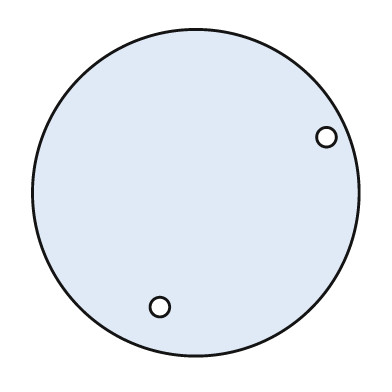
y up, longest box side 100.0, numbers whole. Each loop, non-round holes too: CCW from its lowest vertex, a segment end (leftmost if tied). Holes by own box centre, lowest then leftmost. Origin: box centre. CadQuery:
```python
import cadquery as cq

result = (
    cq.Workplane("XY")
    .moveTo(0.0, 0.0)
    .circle(50.0)
    .moveTo(-11.0, -35.0)
    .circle(3.0)
    .moveTo(40.0, 17.0)
    .circle(3.0)
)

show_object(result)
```